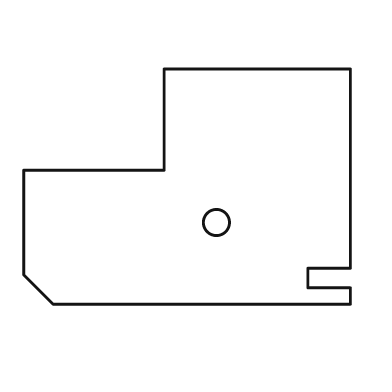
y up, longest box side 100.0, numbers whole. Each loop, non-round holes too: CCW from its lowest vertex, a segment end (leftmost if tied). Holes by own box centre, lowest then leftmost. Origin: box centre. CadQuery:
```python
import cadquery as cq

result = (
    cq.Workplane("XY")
    .moveTo(-41.0, -36.0)
    .lineTo(50.0, -36.0)
    .lineTo(50.0, -31.0)
    .lineTo(37.0, -31.0)
    .lineTo(37.0, -25.0)
    .lineTo(50.0, -25.0)
    .lineTo(50.0, 36.0)
    .lineTo(-7.0, 36.0)
    .lineTo(-7.0, 5.0)
    .lineTo(-50.0, 5.0)
    .lineTo(-50.0, -27.0)
    .close()
    .moveTo(9.0, -11.0)
    .circle(4.0)
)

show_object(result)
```